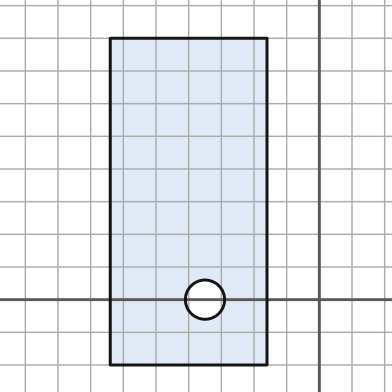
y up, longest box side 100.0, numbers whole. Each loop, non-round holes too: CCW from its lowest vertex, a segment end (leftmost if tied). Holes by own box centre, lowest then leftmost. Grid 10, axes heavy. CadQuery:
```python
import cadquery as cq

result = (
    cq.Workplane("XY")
    .moveTo(-64.0, -20.0)
    .lineTo(-16.0, -20.0)
    .lineTo(-16.0, 80.0)
    .lineTo(-64.0, 80.0)
    .close()
    .moveTo(-35.0, 0.0)
    .circle(6.0)
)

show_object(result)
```